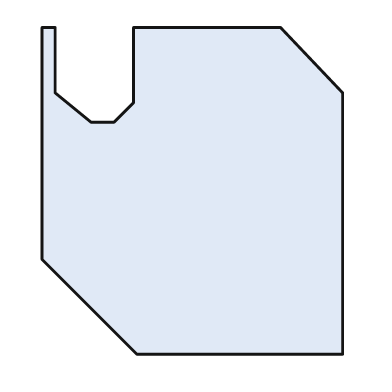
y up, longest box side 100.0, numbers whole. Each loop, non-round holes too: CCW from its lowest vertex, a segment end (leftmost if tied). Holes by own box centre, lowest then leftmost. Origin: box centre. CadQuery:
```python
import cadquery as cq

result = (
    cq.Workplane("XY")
    .moveTo(-17.0, -50.0)
    .lineTo(46.0, -50.0)
    .lineTo(46.0, 30.0)
    .lineTo(27.0, 50.0)
    .lineTo(-18.0, 50.0)
    .lineTo(-18.0, 27.0)
    .lineTo(-24.0, 21.0)
    .lineTo(-31.0, 21.0)
    .lineTo(-42.0, 30.0)
    .lineTo(-42.0, 50.0)
    .lineTo(-46.0, 50.0)
    .lineTo(-46.0, -21.0)
    .close()
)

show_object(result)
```